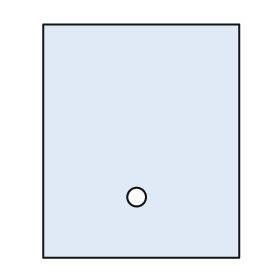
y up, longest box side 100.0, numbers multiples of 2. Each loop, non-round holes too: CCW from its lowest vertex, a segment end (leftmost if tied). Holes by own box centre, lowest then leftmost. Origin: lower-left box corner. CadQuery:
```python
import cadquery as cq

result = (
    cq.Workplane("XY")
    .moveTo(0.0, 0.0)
    .lineTo(84.0, 0.0)
    .lineTo(84.0, 100.0)
    .lineTo(0.0, 100.0)
    .close()
    .moveTo(40.0, 26.0)
    .circle(4.0)
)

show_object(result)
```